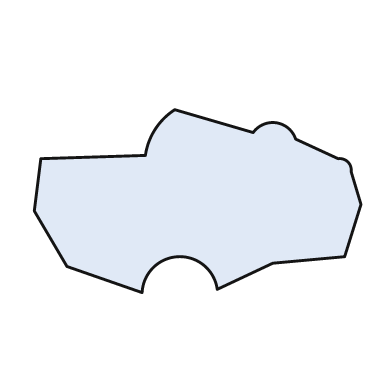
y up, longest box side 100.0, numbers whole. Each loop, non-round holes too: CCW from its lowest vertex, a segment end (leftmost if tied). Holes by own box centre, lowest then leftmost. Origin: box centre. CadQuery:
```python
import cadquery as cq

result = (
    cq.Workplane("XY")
    .moveTo(-17.0, -28.0)
    .threePointArc((-6.0, -17.0), (6.0, -27.0))
    .lineTo(23.0, -19.0)
    .lineTo(45.0, -17.0)
    .lineTo(50.0, -1.0)
    .lineTo(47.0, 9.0)
    .threePointArc((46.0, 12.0), (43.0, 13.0))
    .lineTo(30.0, 19.0)
    .threePointArc((24.0, 24.0), (17.0, 21.0))
    .lineTo(-7.0, 28.0)
    .threePointArc((-13.0, 22.0), (-16.0, 14.0))
    .lineTo(-48.0, 13.0)
    .lineTo(-50.0, -3.0)
    .lineTo(-40.0, -20.0)
    .close()
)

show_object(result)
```